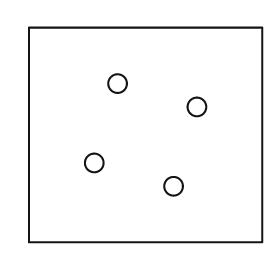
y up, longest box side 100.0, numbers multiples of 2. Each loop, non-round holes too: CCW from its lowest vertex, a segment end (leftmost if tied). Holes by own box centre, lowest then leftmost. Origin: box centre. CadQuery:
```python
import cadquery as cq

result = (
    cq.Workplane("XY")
    .moveTo(-50.0, -46.0)
    .lineTo(50.0, -46.0)
    .lineTo(50.0, 46.0)
    .lineTo(-50.0, 46.0)
    .close()
    .moveTo(12.0, -22.0)
    .circle(4.0)
    .moveTo(-22.0, -12.0)
    .circle(4.0)
    .moveTo(22.0, 12.0)
    .circle(4.0)
    .moveTo(-12.0, 22.0)
    .circle(4.0)
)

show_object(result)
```